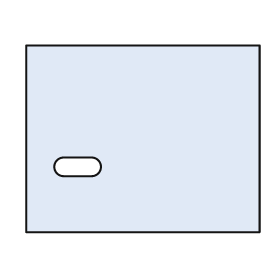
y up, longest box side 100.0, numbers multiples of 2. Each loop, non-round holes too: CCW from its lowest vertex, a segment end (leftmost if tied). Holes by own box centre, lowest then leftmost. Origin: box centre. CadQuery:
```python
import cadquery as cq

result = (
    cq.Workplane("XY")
    .moveTo(-50.0, -40.0)
    .lineTo(50.0, -40.0)
    .lineTo(50.0, 40.0)
    .lineTo(-50.0, 40.0)
    .close()
    .moveTo(-34.0, -16.0)
    .lineTo(-22.0, -16.0)
    .threePointArc((-18.0, -12.0), (-22.0, -8.0))
    .lineTo(-34.0, -8.0)
    .threePointArc((-38.0, -12.0), (-34.0, -16.0))
    .close()
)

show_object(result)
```